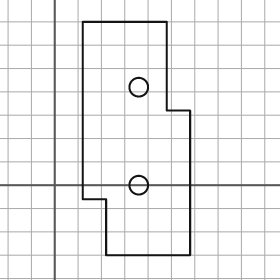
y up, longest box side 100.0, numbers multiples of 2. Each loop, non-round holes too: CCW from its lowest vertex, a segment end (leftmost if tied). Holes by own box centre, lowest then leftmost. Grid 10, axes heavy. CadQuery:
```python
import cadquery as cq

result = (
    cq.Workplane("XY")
    .moveTo(22.0, -30.0)
    .lineTo(58.0, -30.0)
    .lineTo(58.0, 32.0)
    .lineTo(48.0, 32.0)
    .lineTo(48.0, 70.0)
    .lineTo(12.0, 70.0)
    .lineTo(12.0, -6.0)
    .lineTo(22.0, -6.0)
    .close()
    .moveTo(36.0, 0.0)
    .circle(4.0)
    .moveTo(36.0, 42.0)
    .circle(4.0)
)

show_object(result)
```